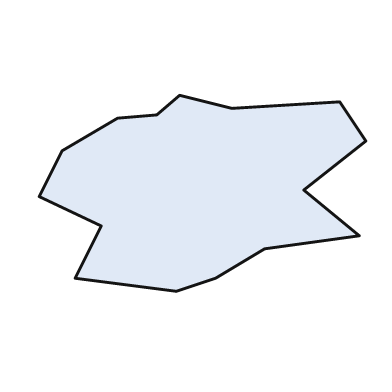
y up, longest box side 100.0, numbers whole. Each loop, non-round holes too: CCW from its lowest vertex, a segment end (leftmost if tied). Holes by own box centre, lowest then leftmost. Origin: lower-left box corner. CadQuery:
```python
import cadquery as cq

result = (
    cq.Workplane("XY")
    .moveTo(42.0, 0.0)
    .lineTo(54.0, 4.0)
    .lineTo(69.0, 13.0)
    .lineTo(98.0, 17.0)
    .lineTo(81.0, 31.0)
    .lineTo(100.0, 46.0)
    .lineTo(92.0, 58.0)
    .lineTo(59.0, 56.0)
    .lineTo(43.0, 60.0)
    .lineTo(36.0, 54.0)
    .lineTo(24.0, 53.0)
    .lineTo(7.0, 43.0)
    .lineTo(0.0, 29.0)
    .lineTo(19.0, 20.0)
    .lineTo(11.0, 4.0)
    .close()
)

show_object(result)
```